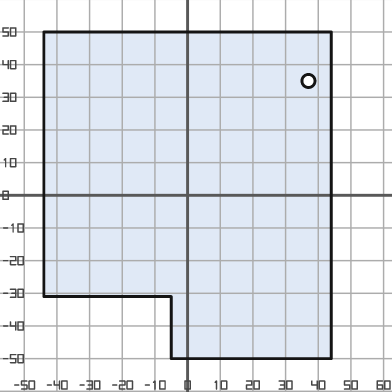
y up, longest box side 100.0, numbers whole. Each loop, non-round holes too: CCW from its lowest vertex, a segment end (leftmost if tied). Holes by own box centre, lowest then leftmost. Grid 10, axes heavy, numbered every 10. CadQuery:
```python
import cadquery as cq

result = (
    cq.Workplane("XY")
    .moveTo(-5.0, -50.0)
    .lineTo(44.0, -50.0)
    .lineTo(44.0, 50.0)
    .lineTo(-44.0, 50.0)
    .lineTo(-44.0, -31.0)
    .lineTo(-5.0, -31.0)
    .close()
    .moveTo(37.0, 35.0)
    .circle(2.0)
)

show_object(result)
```